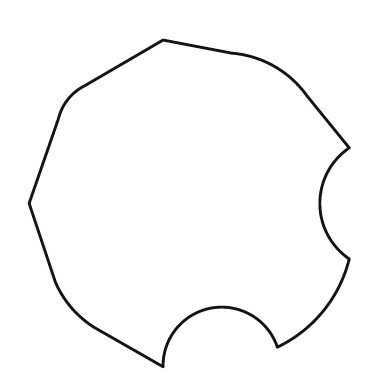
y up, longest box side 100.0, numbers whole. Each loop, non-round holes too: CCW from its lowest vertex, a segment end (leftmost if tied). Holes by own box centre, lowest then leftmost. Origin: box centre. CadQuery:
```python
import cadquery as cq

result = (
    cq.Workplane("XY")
    .moveTo(-8.0, -50.0)
    .threePointArc((7.0, -32.0), (27.0, -44.0))
    .threePointArc((41.0, -33.0), (49.0, -17.0))
    .threePointArc((40.0, 0.0), (49.0, 17.0))
    .lineTo(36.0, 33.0)
    .threePointArc((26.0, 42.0), (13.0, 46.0))
    .lineTo(-8.0, 50.0)
    .lineTo(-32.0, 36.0)
    .threePointArc((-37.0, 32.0), (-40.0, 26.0))
    .lineTo(-49.0, 0.0)
    .lineTo(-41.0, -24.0)
    .threePointArc((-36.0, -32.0), (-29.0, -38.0))
    .close()
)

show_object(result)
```